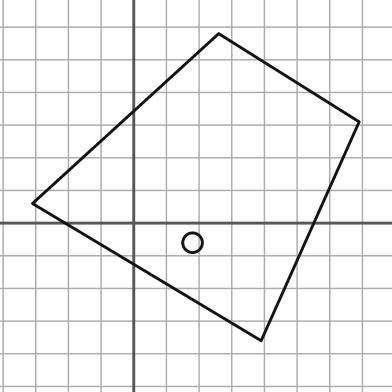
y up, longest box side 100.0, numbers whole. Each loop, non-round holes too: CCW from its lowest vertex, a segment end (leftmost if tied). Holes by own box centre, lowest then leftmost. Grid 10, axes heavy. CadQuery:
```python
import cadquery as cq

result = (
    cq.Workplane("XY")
    .moveTo(39.0, -36.0)
    .lineTo(69.0, 31.0)
    .lineTo(26.0, 58.0)
    .lineTo(-31.0, 6.0)
    .close()
    .moveTo(18.0, -6.0)
    .circle(3.0)
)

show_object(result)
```